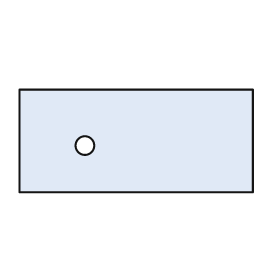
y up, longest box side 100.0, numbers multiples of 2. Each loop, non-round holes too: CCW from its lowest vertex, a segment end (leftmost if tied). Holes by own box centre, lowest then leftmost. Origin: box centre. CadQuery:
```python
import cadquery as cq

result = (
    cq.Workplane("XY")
    .moveTo(-50.0, -22.0)
    .lineTo(50.0, -22.0)
    .lineTo(50.0, 22.0)
    .lineTo(-50.0, 22.0)
    .close()
    .moveTo(-22.0, -2.0)
    .circle(4.0)
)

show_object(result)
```